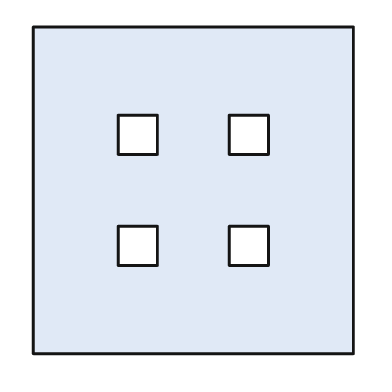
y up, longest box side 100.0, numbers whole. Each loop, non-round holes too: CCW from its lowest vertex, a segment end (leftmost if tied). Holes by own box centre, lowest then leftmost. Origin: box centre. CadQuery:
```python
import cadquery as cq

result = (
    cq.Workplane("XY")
    .moveTo(-49.0, -50.0)
    .lineTo(49.0, -50.0)
    .lineTo(49.0, 50.0)
    .lineTo(-49.0, 50.0)
    .close()
    .moveTo(-23.0, -23.0)
    .lineTo(-11.0, -23.0)
    .lineTo(-11.0, -11.0)
    .lineTo(-23.0, -11.0)
    .close()
    .moveTo(11.0, -23.0)
    .lineTo(23.0, -23.0)
    .lineTo(23.0, -11.0)
    .lineTo(11.0, -11.0)
    .close()
    .moveTo(-23.0, 11.0)
    .lineTo(-11.0, 11.0)
    .lineTo(-11.0, 23.0)
    .lineTo(-23.0, 23.0)
    .close()
    .moveTo(11.0, 11.0)
    .lineTo(23.0, 11.0)
    .lineTo(23.0, 23.0)
    .lineTo(11.0, 23.0)
    .close()
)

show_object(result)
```